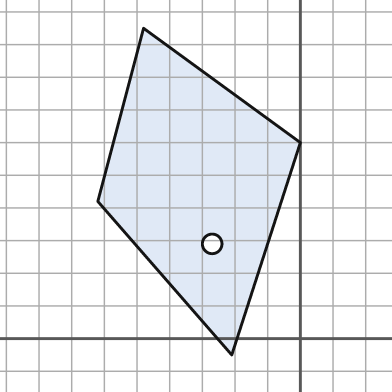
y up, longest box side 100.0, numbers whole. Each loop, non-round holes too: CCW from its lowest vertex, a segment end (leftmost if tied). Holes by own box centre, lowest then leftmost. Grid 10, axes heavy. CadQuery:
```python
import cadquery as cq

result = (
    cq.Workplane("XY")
    .moveTo(-21.0, -5.0)
    .lineTo(0.0, 60.0)
    .lineTo(-48.0, 95.0)
    .lineTo(-62.0, 42.0)
    .close()
    .moveTo(-27.0, 29.0)
    .circle(3.0)
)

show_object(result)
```